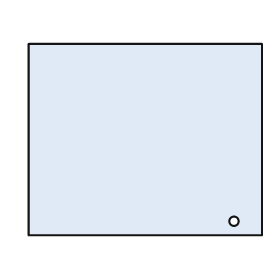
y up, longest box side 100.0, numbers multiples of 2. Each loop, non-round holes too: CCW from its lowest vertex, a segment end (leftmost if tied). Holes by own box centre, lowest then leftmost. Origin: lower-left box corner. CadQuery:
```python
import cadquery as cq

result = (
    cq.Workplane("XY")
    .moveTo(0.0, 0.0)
    .lineTo(100.0, 0.0)
    .lineTo(100.0, 82.0)
    .lineTo(0.0, 82.0)
    .close()
    .moveTo(88.0, 6.0)
    .circle(2.0)
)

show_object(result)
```